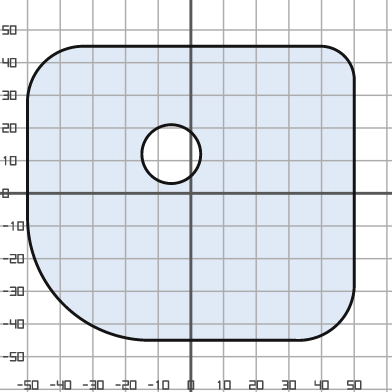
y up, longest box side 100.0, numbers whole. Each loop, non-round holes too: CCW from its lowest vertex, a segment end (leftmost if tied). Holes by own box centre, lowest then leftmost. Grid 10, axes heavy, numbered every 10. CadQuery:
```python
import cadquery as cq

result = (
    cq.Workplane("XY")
    .moveTo(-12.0, -45.0)
    .lineTo(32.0, -45.0)
    .threePointArc((45.0, -40.0), (50.0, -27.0))
    .lineTo(50.0, 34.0)
    .threePointArc((47.0, 42.0), (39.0, 45.0))
    .lineTo(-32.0, 45.0)
    .threePointArc((-45.0, 40.0), (-50.0, 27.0))
    .lineTo(-50.0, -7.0)
    .threePointArc((-39.0, -34.0), (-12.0, -45.0))
    .close()
    .moveTo(-6.0, 12.0)
    .circle(9.0)
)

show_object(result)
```